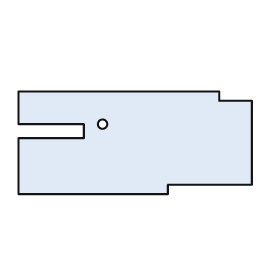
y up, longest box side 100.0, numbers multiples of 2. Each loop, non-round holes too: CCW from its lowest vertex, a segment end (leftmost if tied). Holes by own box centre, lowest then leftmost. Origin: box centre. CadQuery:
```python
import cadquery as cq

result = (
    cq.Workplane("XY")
    .moveTo(-50.0, -22.0)
    .lineTo(14.0, -22.0)
    .lineTo(14.0, -18.0)
    .lineTo(50.0, -18.0)
    .lineTo(50.0, 18.0)
    .lineTo(36.0, 18.0)
    .lineTo(36.0, 22.0)
    .lineTo(-50.0, 22.0)
    .lineTo(-50.0, 8.0)
    .lineTo(-22.0, 8.0)
    .lineTo(-22.0, 2.0)
    .lineTo(-50.0, 2.0)
    .close()
    .moveTo(-14.0, 8.0)
    .circle(2.0)
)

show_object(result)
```